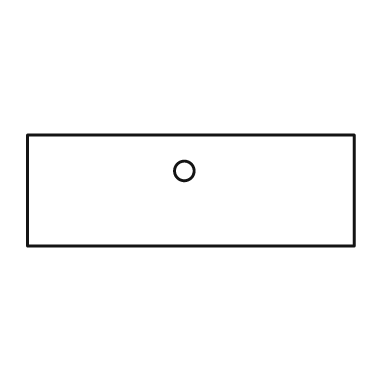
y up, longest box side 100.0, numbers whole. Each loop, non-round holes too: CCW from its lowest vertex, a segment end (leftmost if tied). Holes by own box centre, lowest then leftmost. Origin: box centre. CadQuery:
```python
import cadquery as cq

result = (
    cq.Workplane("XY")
    .moveTo(-50.0, -17.0)
    .lineTo(50.0, -17.0)
    .lineTo(50.0, 17.0)
    .lineTo(-50.0, 17.0)
    .close()
    .moveTo(-2.0, 6.0)
    .circle(3.0)
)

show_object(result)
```